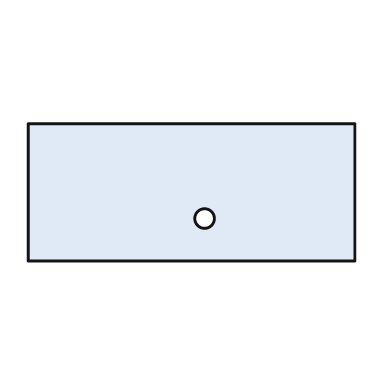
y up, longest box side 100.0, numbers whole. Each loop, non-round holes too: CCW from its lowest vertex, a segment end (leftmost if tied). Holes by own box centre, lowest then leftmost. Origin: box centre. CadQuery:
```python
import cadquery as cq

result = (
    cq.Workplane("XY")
    .moveTo(-50.0, -21.0)
    .lineTo(50.0, -21.0)
    .lineTo(50.0, 21.0)
    .lineTo(-50.0, 21.0)
    .close()
    .moveTo(4.0, -8.0)
    .circle(3.0)
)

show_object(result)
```